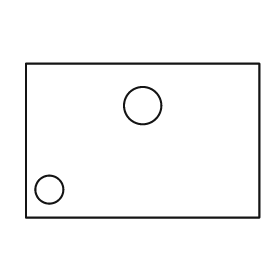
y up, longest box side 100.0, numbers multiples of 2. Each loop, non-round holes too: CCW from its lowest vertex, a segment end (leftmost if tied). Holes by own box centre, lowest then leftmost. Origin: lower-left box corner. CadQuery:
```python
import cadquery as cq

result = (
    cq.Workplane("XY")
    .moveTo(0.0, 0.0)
    .lineTo(100.0, 0.0)
    .lineTo(100.0, 66.0)
    .lineTo(0.0, 66.0)
    .close()
    .moveTo(10.0, 12.0)
    .circle(6.0)
    .moveTo(50.0, 48.0)
    .circle(8.0)
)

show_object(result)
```